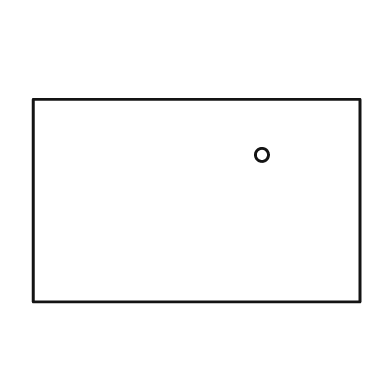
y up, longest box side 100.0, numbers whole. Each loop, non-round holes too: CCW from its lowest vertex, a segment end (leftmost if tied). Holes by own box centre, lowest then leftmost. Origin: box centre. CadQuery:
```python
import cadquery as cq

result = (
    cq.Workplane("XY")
    .moveTo(-50.0, -31.0)
    .lineTo(50.0, -31.0)
    .lineTo(50.0, 31.0)
    .lineTo(-50.0, 31.0)
    .close()
    .moveTo(20.0, 14.0)
    .circle(2.0)
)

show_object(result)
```